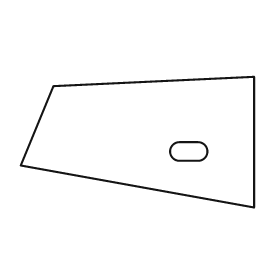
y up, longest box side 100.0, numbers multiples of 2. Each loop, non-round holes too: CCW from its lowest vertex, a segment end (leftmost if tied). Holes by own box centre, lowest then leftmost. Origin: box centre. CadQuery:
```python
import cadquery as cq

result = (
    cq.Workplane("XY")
    .moveTo(50.0, -28.0)
    .lineTo(50.0, 28.0)
    .lineTo(-36.0, 24.0)
    .lineTo(-50.0, -10.0)
    .close()
    .moveTo(18.0, -8.0)
    .lineTo(26.0, -8.0)
    .threePointArc((30.0, -4.0), (26.0, 0.0))
    .lineTo(18.0, 0.0)
    .threePointArc((14.0, -4.0), (18.0, -8.0))
    .close()
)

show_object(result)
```